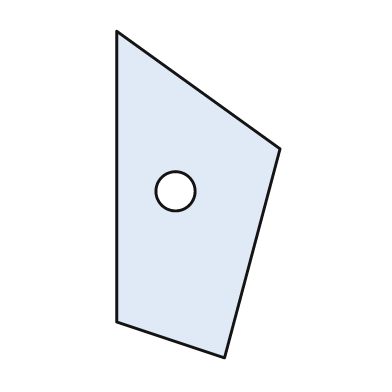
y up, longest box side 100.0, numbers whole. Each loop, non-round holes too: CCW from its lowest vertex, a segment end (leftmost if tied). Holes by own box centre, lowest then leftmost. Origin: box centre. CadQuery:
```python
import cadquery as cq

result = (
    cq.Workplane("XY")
    .moveTo(8.0, -50.0)
    .lineTo(25.0, 14.0)
    .lineTo(-25.0, 50.0)
    .lineTo(-25.0, -39.0)
    .close()
    .moveTo(-7.0, 1.0)
    .circle(6.0)
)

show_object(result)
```